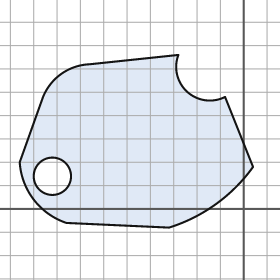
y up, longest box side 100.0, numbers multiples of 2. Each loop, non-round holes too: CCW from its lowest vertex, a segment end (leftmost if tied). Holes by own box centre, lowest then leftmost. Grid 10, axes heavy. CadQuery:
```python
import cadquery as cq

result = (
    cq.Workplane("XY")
    .moveTo(-32.0, -8.0)
    .threePointArc((-12.0, 2.0), (4.0, 18.0))
    .lineTo(-8.0, 48.0)
    .threePointArc((-24.0, 50.0), (-28.0, 66.0))
    .lineTo(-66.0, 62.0)
    .threePointArc((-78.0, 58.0), (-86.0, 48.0))
    .lineTo(-96.0, 20.0)
    .threePointArc((-90.0, 4.0), (-76.0, -6.0))
    .close()
    .moveTo(-82.0, 14.0)
    .circle(8.0)
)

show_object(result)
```